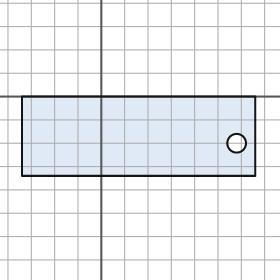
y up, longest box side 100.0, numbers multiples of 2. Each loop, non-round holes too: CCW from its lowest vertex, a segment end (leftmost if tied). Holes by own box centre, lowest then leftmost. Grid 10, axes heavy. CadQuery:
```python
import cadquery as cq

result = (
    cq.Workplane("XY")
    .moveTo(-34.0, -34.0)
    .lineTo(66.0, -34.0)
    .lineTo(66.0, 0.0)
    .lineTo(-34.0, 0.0)
    .close()
    .moveTo(58.0, -20.0)
    .circle(4.0)
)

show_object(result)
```